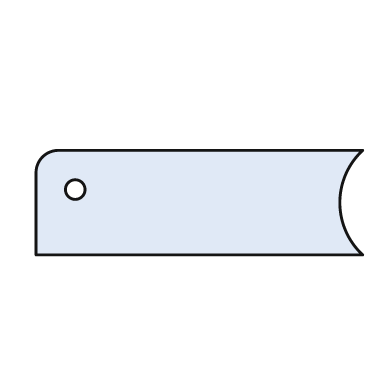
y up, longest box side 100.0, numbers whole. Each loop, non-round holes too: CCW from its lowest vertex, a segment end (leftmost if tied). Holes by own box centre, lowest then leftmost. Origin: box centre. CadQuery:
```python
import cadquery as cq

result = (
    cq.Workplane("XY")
    .moveTo(-50.0, -16.0)
    .lineTo(50.0, -16.0)
    .threePointArc((43.0, 0.0), (50.0, 16.0))
    .lineTo(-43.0, 16.0)
    .threePointArc((-48.0, 14.0), (-50.0, 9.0))
    .close()
    .moveTo(-38.0, 4.0)
    .circle(3.0)
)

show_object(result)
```